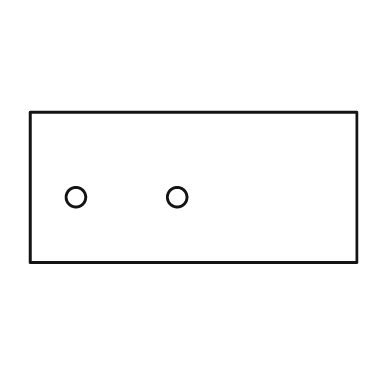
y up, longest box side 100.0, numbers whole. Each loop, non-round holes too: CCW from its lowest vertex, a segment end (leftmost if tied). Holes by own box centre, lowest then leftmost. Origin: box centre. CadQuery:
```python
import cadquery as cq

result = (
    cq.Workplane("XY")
    .moveTo(-50.0, -23.0)
    .lineTo(50.0, -23.0)
    .lineTo(50.0, 23.0)
    .lineTo(-50.0, 23.0)
    .close()
    .moveTo(-36.0, -3.0)
    .circle(3.0)
    .moveTo(-5.0, -3.0)
    .circle(3.0)
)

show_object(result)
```